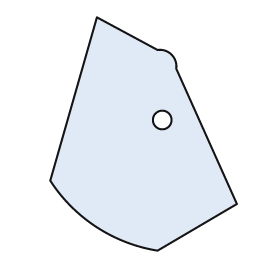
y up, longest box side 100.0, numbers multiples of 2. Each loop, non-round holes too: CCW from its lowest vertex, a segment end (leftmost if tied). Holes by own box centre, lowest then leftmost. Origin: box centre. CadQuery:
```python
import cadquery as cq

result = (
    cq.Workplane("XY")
    .moveTo(6.0, -50.0)
    .lineTo(40.0, -30.0)
    .lineTo(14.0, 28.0)
    .threePointArc((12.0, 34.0), (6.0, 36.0))
    .lineTo(-20.0, 50.0)
    .lineTo(-40.0, -20.0)
    .threePointArc((-20.0, -40.0), (6.0, -50.0))
    .close()
    .moveTo(8.0, 6.0)
    .circle(4.0)
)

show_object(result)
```